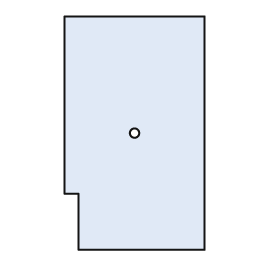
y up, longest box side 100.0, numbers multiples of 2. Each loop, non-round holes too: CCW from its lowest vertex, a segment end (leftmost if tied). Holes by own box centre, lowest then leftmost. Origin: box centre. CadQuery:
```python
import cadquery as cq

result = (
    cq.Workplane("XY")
    .moveTo(-24.0, -50.0)
    .lineTo(30.0, -50.0)
    .lineTo(30.0, 50.0)
    .lineTo(-30.0, 50.0)
    .lineTo(-30.0, -26.0)
    .lineTo(-24.0, -26.0)
    .close()
    .moveTo(0.0, 0.0)
    .circle(2.0)
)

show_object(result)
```